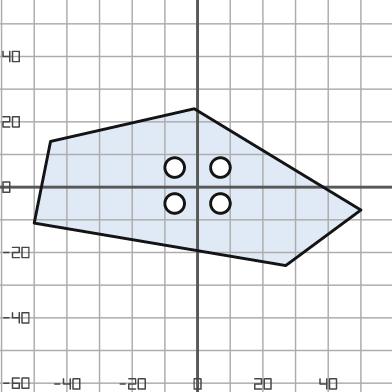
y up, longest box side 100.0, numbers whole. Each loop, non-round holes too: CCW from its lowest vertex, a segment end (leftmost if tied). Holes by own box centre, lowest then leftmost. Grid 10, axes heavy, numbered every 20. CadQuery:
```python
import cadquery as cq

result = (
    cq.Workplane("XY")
    .moveTo(27.0, -24.0)
    .lineTo(50.0, -7.0)
    .lineTo(-1.0, 24.0)
    .lineTo(-45.0, 14.0)
    .lineTo(-50.0, -11.0)
    .close()
    .moveTo(-7.0, -5.0)
    .circle(3.0)
    .moveTo(7.0, -5.0)
    .circle(3.0)
    .moveTo(-7.0, 6.0)
    .circle(3.0)
    .moveTo(7.0, 6.0)
    .circle(3.0)
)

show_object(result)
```